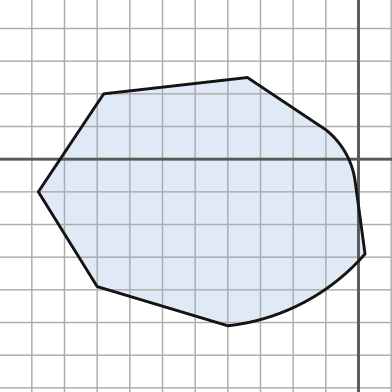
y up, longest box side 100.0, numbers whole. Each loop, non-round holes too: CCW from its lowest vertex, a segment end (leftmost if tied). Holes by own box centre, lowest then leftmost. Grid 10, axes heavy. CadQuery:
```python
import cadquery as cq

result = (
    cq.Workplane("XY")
    .moveTo(-40.0, -51.0)
    .threePointArc((-17.0, -44.0), (2.0, -29.0))
    .lineTo(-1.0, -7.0)
    .threePointArc((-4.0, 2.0), (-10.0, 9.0))
    .lineTo(-34.0, 25.0)
    .lineTo(-78.0, 20.0)
    .lineTo(-98.0, -10.0)
    .lineTo(-80.0, -39.0)
    .close()
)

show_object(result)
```